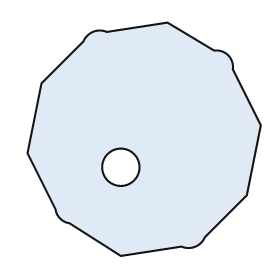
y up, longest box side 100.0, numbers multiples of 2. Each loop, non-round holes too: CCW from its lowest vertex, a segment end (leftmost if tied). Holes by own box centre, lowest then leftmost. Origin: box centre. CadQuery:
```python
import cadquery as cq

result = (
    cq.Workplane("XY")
    .moveTo(-10.0, -50.0)
    .lineTo(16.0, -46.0)
    .threePointArc((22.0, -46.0), (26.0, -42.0))
    .lineTo(44.0, -24.0)
    .lineTo(50.0, 6.0)
    .lineTo(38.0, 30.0)
    .threePointArc((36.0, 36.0), (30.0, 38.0))
    .lineTo(10.0, 50.0)
    .lineTo(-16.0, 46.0)
    .threePointArc((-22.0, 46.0), (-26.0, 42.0))
    .lineTo(-44.0, 24.0)
    .lineTo(-50.0, -6.0)
    .lineTo(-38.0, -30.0)
    .threePointArc((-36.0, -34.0), (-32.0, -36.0))
    .close()
    .moveTo(-10.0, -12.0)
    .circle(8.0)
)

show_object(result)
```